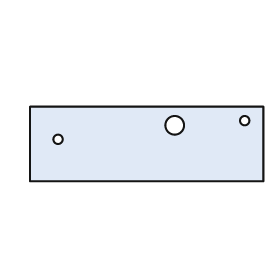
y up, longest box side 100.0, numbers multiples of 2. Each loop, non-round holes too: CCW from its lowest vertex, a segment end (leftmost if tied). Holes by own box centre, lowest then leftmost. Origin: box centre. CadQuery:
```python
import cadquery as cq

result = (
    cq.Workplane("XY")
    .moveTo(-50.0, -16.0)
    .lineTo(50.0, -16.0)
    .lineTo(50.0, 16.0)
    .lineTo(-50.0, 16.0)
    .close()
    .moveTo(-38.0, 2.0)
    .circle(2.0)
    .moveTo(12.0, 8.0)
    .circle(4.0)
    .moveTo(42.0, 10.0)
    .circle(2.0)
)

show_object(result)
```